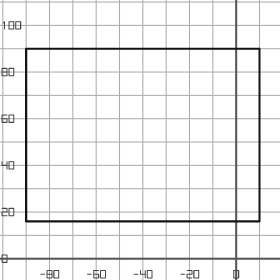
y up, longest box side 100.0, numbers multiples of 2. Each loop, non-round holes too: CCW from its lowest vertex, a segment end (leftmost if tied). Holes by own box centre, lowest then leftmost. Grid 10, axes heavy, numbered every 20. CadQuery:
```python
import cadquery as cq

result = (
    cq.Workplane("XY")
    .moveTo(-90.0, 16.0)
    .lineTo(10.0, 16.0)
    .lineTo(10.0, 90.0)
    .lineTo(-90.0, 90.0)
    .close()
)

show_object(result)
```